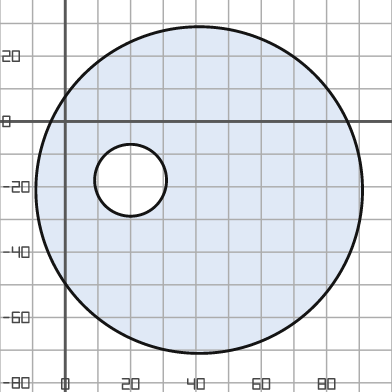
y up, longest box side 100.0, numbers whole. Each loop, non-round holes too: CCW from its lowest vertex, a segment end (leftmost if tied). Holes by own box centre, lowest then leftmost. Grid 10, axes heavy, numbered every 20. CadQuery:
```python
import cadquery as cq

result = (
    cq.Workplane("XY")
    .moveTo(41.0, -21.0)
    .circle(50.0)
    .moveTo(20.0, -18.0)
    .circle(11.0)
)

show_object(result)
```